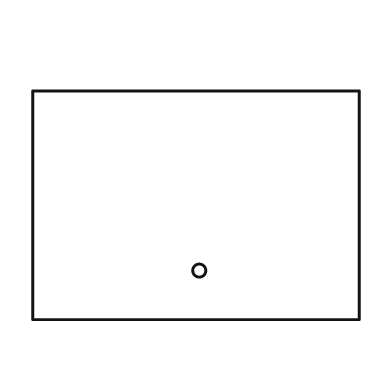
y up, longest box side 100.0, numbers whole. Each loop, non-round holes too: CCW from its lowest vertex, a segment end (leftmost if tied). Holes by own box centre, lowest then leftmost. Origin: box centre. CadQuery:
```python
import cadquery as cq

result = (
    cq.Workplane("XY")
    .moveTo(-50.0, -35.0)
    .lineTo(50.0, -35.0)
    .lineTo(50.0, 35.0)
    .lineTo(-50.0, 35.0)
    .close()
    .moveTo(1.0, -20.0)
    .circle(2.0)
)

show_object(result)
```